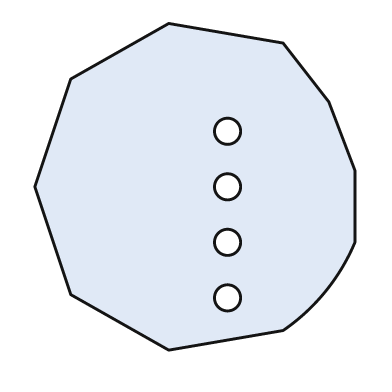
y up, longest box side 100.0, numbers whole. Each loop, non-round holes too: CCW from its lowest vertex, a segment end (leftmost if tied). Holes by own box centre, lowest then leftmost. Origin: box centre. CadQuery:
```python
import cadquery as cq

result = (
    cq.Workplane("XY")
    .moveTo(-8.0, -50.0)
    .lineTo(27.0, -44.0)
    .threePointArc((40.0, -32.0), (49.0, -17.0))
    .lineTo(49.0, 5.0)
    .lineTo(41.0, 26.0)
    .lineTo(27.0, 44.0)
    .lineTo(-8.0, 50.0)
    .lineTo(-38.0, 33.0)
    .lineTo(-49.0, 0.0)
    .lineTo(-38.0, -33.0)
    .close()
    .moveTo(10.0, -34.0)
    .circle(4.0)
    .moveTo(10.0, -17.0)
    .circle(4.0)
    .moveTo(10.0, 0.0)
    .circle(4.0)
    .moveTo(10.0, 17.0)
    .circle(4.0)
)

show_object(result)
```